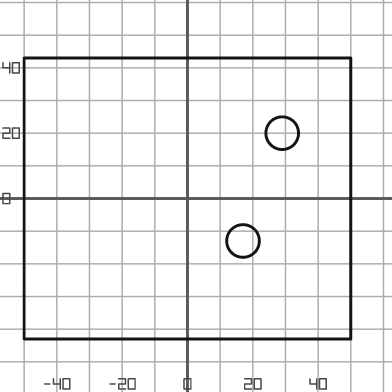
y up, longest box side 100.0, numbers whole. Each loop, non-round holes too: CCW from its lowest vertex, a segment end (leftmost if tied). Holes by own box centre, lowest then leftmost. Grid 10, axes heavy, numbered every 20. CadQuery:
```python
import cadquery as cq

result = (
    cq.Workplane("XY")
    .moveTo(-50.0, -43.0)
    .lineTo(50.0, -43.0)
    .lineTo(50.0, 43.0)
    .lineTo(-50.0, 43.0)
    .close()
    .moveTo(17.0, -13.0)
    .circle(5.0)
    .moveTo(29.0, 20.0)
    .circle(5.0)
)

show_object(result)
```